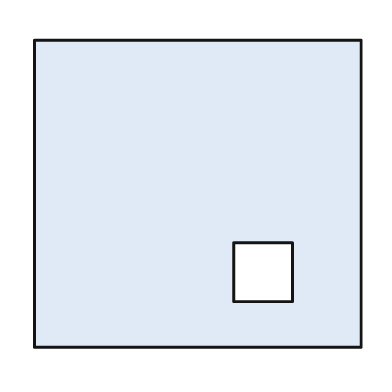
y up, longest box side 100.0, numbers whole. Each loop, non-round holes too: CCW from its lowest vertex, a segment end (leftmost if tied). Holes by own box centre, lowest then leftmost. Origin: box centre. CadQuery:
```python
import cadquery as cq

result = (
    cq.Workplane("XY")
    .moveTo(-50.0, -47.0)
    .lineTo(50.0, -47.0)
    .lineTo(50.0, 47.0)
    .lineTo(-50.0, 47.0)
    .close()
    .moveTo(11.0, -33.0)
    .lineTo(29.0, -33.0)
    .lineTo(29.0, -15.0)
    .lineTo(11.0, -15.0)
    .close()
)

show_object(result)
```